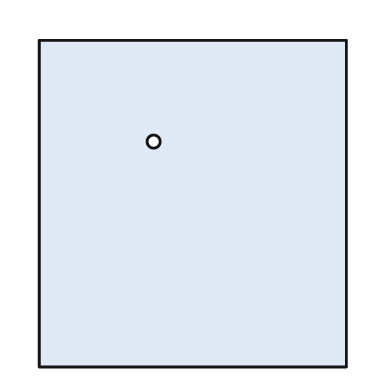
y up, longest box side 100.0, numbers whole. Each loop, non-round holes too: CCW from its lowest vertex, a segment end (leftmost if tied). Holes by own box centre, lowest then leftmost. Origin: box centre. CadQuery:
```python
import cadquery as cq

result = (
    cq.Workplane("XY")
    .moveTo(-47.0, -50.0)
    .lineTo(47.0, -50.0)
    .lineTo(47.0, 50.0)
    .lineTo(-47.0, 50.0)
    .close()
    .moveTo(-12.0, 19.0)
    .circle(2.0)
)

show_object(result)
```